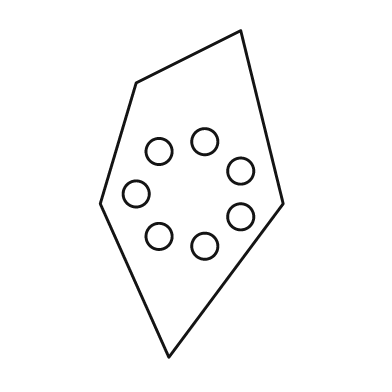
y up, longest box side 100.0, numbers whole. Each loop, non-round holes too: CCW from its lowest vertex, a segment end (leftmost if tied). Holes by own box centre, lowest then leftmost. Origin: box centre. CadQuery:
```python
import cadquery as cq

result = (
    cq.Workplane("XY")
    .moveTo(-7.0, -50.0)
    .lineTo(28.0, -3.0)
    .lineTo(15.0, 50.0)
    .lineTo(-17.0, 34.0)
    .lineTo(-28.0, -3.0)
    .close()
    .moveTo(4.0, -16.0)
    .circle(4.0)
    .moveTo(-10.0, -13.0)
    .circle(4.0)
    .moveTo(15.0, -7.0)
    .circle(4.0)
    .moveTo(-17.0, 0.0)
    .circle(4.0)
    .moveTo(15.0, 7.0)
    .circle(4.0)
    .moveTo(-10.0, 13.0)
    .circle(4.0)
    .moveTo(4.0, 16.0)
    .circle(4.0)
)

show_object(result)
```